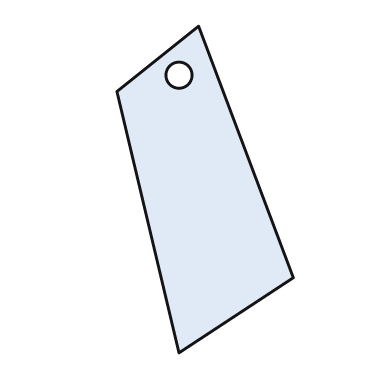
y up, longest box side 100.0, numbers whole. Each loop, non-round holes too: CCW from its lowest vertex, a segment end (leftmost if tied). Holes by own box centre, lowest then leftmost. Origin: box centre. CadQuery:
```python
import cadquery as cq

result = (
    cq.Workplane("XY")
    .moveTo(-8.0, -50.0)
    .lineTo(27.0, -27.0)
    .lineTo(-2.0, 50.0)
    .lineTo(-27.0, 30.0)
    .close()
    .moveTo(-8.0, 35.0)
    .circle(4.0)
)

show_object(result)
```